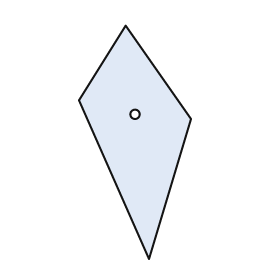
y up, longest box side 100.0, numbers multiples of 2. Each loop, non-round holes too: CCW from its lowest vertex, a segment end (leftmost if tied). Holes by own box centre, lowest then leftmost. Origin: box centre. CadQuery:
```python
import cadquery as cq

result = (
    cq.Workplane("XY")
    .moveTo(6.0, -50.0)
    .lineTo(24.0, 10.0)
    .lineTo(-4.0, 50.0)
    .lineTo(-24.0, 18.0)
    .close()
    .moveTo(0.0, 12.0)
    .circle(2.0)
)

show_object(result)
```